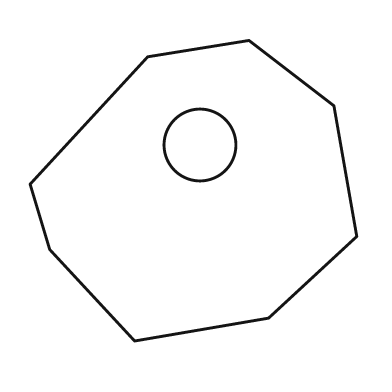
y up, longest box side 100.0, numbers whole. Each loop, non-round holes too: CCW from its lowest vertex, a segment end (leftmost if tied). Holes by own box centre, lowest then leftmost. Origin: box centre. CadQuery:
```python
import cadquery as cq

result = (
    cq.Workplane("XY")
    .moveTo(-18.0, -46.0)
    .lineTo(23.0, -39.0)
    .lineTo(50.0, -14.0)
    .lineTo(43.0, 26.0)
    .lineTo(17.0, 46.0)
    .lineTo(-14.0, 41.0)
    .lineTo(-50.0, 2.0)
    .lineTo(-44.0, -18.0)
    .close()
    .moveTo(2.0, 14.0)
    .circle(11.0)
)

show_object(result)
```